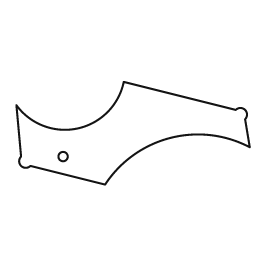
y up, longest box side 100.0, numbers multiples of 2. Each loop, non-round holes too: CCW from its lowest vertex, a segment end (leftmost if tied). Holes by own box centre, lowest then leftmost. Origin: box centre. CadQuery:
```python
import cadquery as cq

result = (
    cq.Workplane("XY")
    .moveTo(-12.0, -22.0)
    .threePointArc((16.0, -2.0), (50.0, -6.0))
    .lineTo(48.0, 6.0)
    .threePointArc((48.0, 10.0), (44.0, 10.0))
    .lineTo(-4.0, 22.0)
    .threePointArc((-24.0, 2.0), (-50.0, 12.0))
    .lineTo(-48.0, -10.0)
    .threePointArc((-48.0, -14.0), (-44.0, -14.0))
    .close()
    .moveTo(-30.0, -10.0)
    .circle(2.0)
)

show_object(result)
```